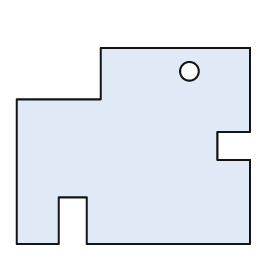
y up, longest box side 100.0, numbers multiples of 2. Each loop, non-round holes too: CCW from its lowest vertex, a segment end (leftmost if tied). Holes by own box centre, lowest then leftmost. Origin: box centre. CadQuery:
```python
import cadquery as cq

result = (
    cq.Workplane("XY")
    .moveTo(-50.0, -42.0)
    .lineTo(-32.0, -42.0)
    .lineTo(-32.0, -22.0)
    .lineTo(-20.0, -22.0)
    .lineTo(-20.0, -42.0)
    .lineTo(50.0, -42.0)
    .lineTo(50.0, -6.0)
    .lineTo(36.0, -6.0)
    .lineTo(36.0, 6.0)
    .lineTo(50.0, 6.0)
    .lineTo(50.0, 42.0)
    .lineTo(-14.0, 42.0)
    .lineTo(-14.0, 20.0)
    .lineTo(-50.0, 20.0)
    .close()
    .moveTo(24.0, 32.0)
    .circle(4.0)
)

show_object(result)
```